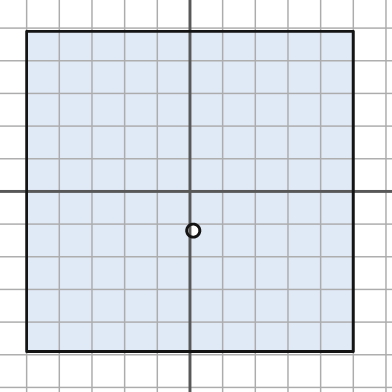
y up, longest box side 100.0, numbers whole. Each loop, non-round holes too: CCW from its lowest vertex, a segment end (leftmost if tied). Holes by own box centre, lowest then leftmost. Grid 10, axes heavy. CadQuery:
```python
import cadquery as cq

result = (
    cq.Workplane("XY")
    .moveTo(-50.0, -49.0)
    .lineTo(50.0, -49.0)
    .lineTo(50.0, 49.0)
    .lineTo(-50.0, 49.0)
    .close()
    .moveTo(1.0, -12.0)
    .circle(2.0)
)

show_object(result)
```